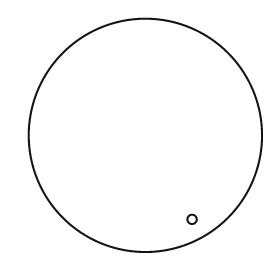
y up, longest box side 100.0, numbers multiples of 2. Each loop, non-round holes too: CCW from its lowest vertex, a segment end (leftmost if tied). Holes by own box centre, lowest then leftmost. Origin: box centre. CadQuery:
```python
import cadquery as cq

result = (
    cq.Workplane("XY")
    .moveTo(0.0, 0.0)
    .circle(50.0)
    .moveTo(20.0, -36.0)
    .circle(2.0)
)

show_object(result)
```